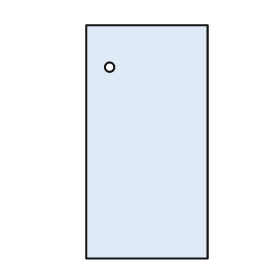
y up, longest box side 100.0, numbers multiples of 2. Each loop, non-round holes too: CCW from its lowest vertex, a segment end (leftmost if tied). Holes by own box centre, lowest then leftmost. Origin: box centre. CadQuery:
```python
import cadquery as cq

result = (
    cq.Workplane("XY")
    .moveTo(-26.0, -50.0)
    .lineTo(26.0, -50.0)
    .lineTo(26.0, 50.0)
    .lineTo(-26.0, 50.0)
    .close()
    .moveTo(-16.0, 32.0)
    .circle(2.0)
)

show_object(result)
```